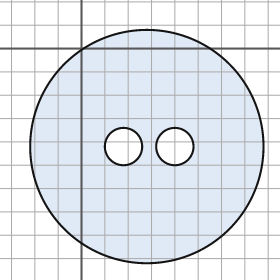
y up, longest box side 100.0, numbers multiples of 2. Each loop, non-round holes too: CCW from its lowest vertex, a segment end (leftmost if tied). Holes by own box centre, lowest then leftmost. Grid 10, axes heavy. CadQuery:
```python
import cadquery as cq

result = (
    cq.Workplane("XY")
    .moveTo(28.0, -42.0)
    .circle(50.0)
    .moveTo(18.0, -42.0)
    .circle(8.0)
    .moveTo(40.0, -42.0)
    .circle(8.0)
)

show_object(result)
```